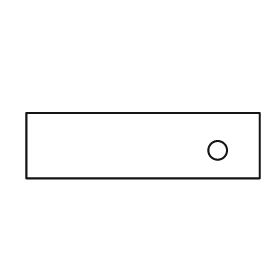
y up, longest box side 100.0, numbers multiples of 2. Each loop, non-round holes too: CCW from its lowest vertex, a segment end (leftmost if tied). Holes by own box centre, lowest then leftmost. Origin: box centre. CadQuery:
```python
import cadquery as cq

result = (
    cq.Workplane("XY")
    .moveTo(-50.0, -14.0)
    .lineTo(50.0, -14.0)
    .lineTo(50.0, 14.0)
    .lineTo(-50.0, 14.0)
    .close()
    .moveTo(32.0, -2.0)
    .circle(4.0)
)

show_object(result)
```